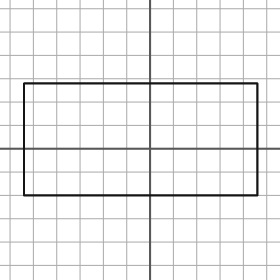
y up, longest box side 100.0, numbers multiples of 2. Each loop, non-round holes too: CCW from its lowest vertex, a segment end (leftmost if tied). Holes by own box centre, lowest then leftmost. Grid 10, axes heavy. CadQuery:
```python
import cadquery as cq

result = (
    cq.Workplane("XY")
    .moveTo(-54.0, -20.0)
    .lineTo(46.0, -20.0)
    .lineTo(46.0, 28.0)
    .lineTo(-54.0, 28.0)
    .close()
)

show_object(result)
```